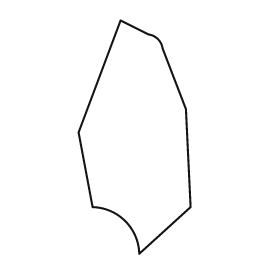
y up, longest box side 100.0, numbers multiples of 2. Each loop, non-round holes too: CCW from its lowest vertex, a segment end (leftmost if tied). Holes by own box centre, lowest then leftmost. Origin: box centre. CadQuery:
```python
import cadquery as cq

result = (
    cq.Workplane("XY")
    .moveTo(2.0, -50.0)
    .lineTo(24.0, -30.0)
    .lineTo(22.0, 12.0)
    .lineTo(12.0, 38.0)
    .threePointArc((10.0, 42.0), (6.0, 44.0))
    .lineTo(-6.0, 50.0)
    .lineTo(-24.0, 2.0)
    .lineTo(-18.0, -30.0)
    .threePointArc((-4.0, -36.0), (2.0, -50.0))
    .close()
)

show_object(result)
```